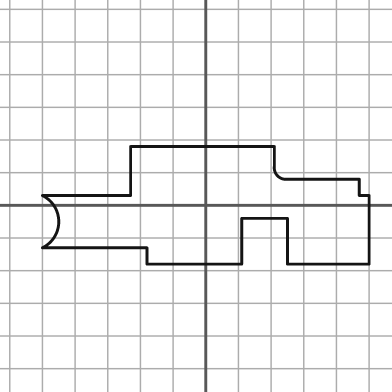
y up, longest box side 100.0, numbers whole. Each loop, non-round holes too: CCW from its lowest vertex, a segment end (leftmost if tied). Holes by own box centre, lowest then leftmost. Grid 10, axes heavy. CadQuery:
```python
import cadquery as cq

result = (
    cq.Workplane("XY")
    .moveTo(-18.0, -18.0)
    .lineTo(11.0, -18.0)
    .lineTo(11.0, -4.0)
    .lineTo(25.0, -4.0)
    .lineTo(25.0, -18.0)
    .lineTo(50.0, -18.0)
    .lineTo(50.0, 3.0)
    .lineTo(47.0, 3.0)
    .lineTo(47.0, 8.0)
    .lineTo(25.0, 8.0)
    .threePointArc((22.0, 9.0), (21.0, 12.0))
    .lineTo(21.0, 18.0)
    .lineTo(-23.0, 18.0)
    .lineTo(-23.0, 3.0)
    .lineTo(-50.0, 3.0)
    .threePointArc((-45.0, -5.0), (-50.0, -13.0))
    .lineTo(-18.0, -13.0)
    .close()
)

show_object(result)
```